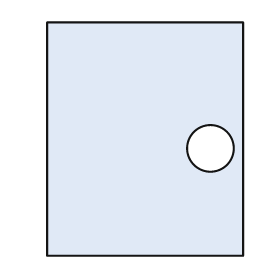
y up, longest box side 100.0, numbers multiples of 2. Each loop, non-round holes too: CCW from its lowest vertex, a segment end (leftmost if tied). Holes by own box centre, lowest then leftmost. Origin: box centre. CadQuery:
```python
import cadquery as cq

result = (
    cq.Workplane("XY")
    .moveTo(-42.0, -50.0)
    .lineTo(42.0, -50.0)
    .lineTo(42.0, 50.0)
    .lineTo(-42.0, 50.0)
    .close()
    .moveTo(28.0, -4.0)
    .circle(10.0)
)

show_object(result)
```